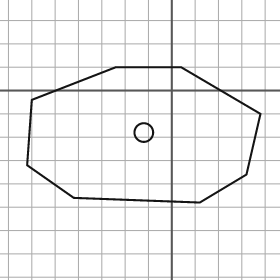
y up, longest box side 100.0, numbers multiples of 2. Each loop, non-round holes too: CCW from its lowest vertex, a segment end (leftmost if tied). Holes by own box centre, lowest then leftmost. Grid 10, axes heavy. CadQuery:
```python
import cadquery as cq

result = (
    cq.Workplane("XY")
    .moveTo(12.0, -48.0)
    .lineTo(32.0, -36.0)
    .lineTo(38.0, -10.0)
    .lineTo(4.0, 10.0)
    .lineTo(-24.0, 10.0)
    .lineTo(-60.0, -4.0)
    .lineTo(-62.0, -32.0)
    .lineTo(-42.0, -46.0)
    .close()
    .moveTo(-12.0, -18.0)
    .circle(4.0)
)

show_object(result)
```